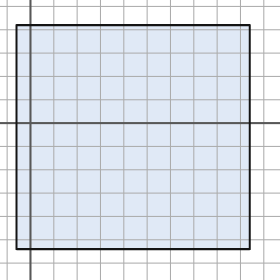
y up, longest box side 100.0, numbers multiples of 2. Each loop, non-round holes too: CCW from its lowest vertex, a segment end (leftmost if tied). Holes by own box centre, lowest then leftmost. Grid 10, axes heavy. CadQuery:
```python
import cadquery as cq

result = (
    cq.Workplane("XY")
    .moveTo(-6.0, -54.0)
    .lineTo(94.0, -54.0)
    .lineTo(94.0, 42.0)
    .lineTo(-6.0, 42.0)
    .close()
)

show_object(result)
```